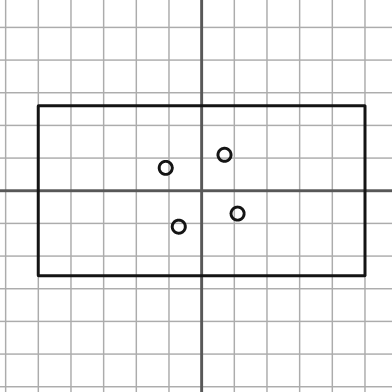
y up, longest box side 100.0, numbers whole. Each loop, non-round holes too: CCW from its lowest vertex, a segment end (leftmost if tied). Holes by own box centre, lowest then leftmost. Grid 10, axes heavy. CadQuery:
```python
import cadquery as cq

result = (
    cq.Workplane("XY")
    .moveTo(-50.0, -26.0)
    .lineTo(50.0, -26.0)
    .lineTo(50.0, 26.0)
    .lineTo(-50.0, 26.0)
    .close()
    .moveTo(-7.0, -11.0)
    .circle(2.0)
    .moveTo(11.0, -7.0)
    .circle(2.0)
    .moveTo(-11.0, 7.0)
    .circle(2.0)
    .moveTo(7.0, 11.0)
    .circle(2.0)
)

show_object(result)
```